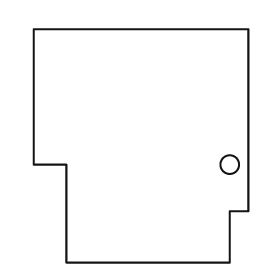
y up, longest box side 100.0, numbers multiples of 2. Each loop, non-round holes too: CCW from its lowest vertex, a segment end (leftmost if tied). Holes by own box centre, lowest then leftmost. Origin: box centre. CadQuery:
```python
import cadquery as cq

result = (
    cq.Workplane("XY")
    .moveTo(-32.0, -50.0)
    .lineTo(38.0, -50.0)
    .lineTo(38.0, -28.0)
    .lineTo(46.0, -28.0)
    .lineTo(46.0, 50.0)
    .lineTo(-46.0, 50.0)
    .lineTo(-46.0, -8.0)
    .lineTo(-32.0, -8.0)
    .close()
    .moveTo(38.0, -8.0)
    .circle(4.0)
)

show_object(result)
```